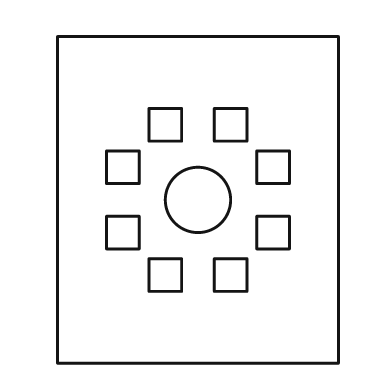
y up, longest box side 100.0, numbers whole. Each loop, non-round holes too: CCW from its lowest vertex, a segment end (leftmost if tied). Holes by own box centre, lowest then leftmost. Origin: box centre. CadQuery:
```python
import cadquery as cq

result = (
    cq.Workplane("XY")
    .moveTo(-43.0, -50.0)
    .lineTo(43.0, -50.0)
    .lineTo(43.0, 50.0)
    .lineTo(-43.0, 50.0)
    .close()
    .moveTo(-15.0, -28.0)
    .lineTo(-5.0, -28.0)
    .lineTo(-5.0, -18.0)
    .lineTo(-15.0, -18.0)
    .close()
    .moveTo(5.0, -28.0)
    .lineTo(15.0, -28.0)
    .lineTo(15.0, -18.0)
    .lineTo(5.0, -18.0)
    .close()
    .moveTo(-28.0, -15.0)
    .lineTo(-18.0, -15.0)
    .lineTo(-18.0, -5.0)
    .lineTo(-28.0, -5.0)
    .close()
    .moveTo(18.0, -15.0)
    .lineTo(28.0, -15.0)
    .lineTo(28.0, -5.0)
    .lineTo(18.0, -5.0)
    .close()
    .moveTo(0.0, 0.0)
    .circle(10.0)
    .moveTo(-28.0, 5.0)
    .lineTo(-18.0, 5.0)
    .lineTo(-18.0, 15.0)
    .lineTo(-28.0, 15.0)
    .close()
    .moveTo(18.0, 5.0)
    .lineTo(28.0, 5.0)
    .lineTo(28.0, 15.0)
    .lineTo(18.0, 15.0)
    .close()
    .moveTo(-15.0, 18.0)
    .lineTo(-5.0, 18.0)
    .lineTo(-5.0, 28.0)
    .lineTo(-15.0, 28.0)
    .close()
    .moveTo(5.0, 18.0)
    .lineTo(15.0, 18.0)
    .lineTo(15.0, 28.0)
    .lineTo(5.0, 28.0)
    .close()
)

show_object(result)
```